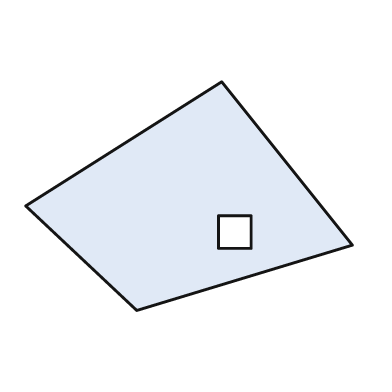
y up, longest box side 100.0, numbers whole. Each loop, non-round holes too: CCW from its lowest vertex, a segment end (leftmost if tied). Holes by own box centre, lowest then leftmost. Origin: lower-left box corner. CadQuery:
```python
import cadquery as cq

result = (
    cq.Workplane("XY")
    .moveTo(34.0, 0.0)
    .lineTo(100.0, 20.0)
    .lineTo(60.0, 70.0)
    .lineTo(0.0, 32.0)
    .close()
    .moveTo(59.0, 19.0)
    .lineTo(69.0, 19.0)
    .lineTo(69.0, 29.0)
    .lineTo(59.0, 29.0)
    .close()
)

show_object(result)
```